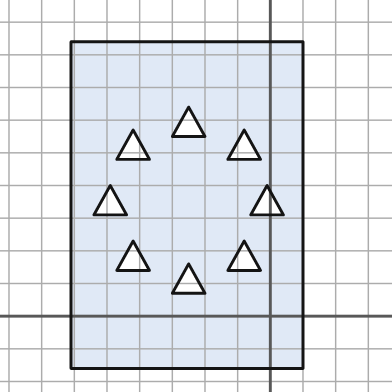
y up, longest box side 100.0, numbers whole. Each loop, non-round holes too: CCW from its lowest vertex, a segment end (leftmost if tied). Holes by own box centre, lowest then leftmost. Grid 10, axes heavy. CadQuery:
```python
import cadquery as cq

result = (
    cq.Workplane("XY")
    .moveTo(-61.0, -16.0)
    .lineTo(10.0, -16.0)
    .lineTo(10.0, 84.0)
    .lineTo(-61.0, 84.0)
    .close()
    .moveTo(-30.0, 7.0)
    .lineTo(-20.0, 7.0)
    .lineTo(-25.0, 16.0)
    .close()
    .moveTo(-47.0, 14.0)
    .lineTo(-37.0, 14.0)
    .lineTo(-42.0, 23.0)
    .close()
    .moveTo(-13.0, 14.0)
    .lineTo(-3.0, 14.0)
    .lineTo(-8.0, 23.0)
    .close()
    .moveTo(-54.0, 31.0)
    .lineTo(-44.0, 31.0)
    .lineTo(-49.0, 40.0)
    .close()
    .moveTo(-6.0, 31.0)
    .lineTo(4.0, 31.0)
    .lineTo(-1.0, 40.0)
    .close()
    .moveTo(-47.0, 48.0)
    .lineTo(-37.0, 48.0)
    .lineTo(-42.0, 57.0)
    .close()
    .moveTo(-13.0, 48.0)
    .lineTo(-3.0, 48.0)
    .lineTo(-8.0, 57.0)
    .close()
    .moveTo(-30.0, 55.0)
    .lineTo(-20.0, 55.0)
    .lineTo(-25.0, 64.0)
    .close()
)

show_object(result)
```